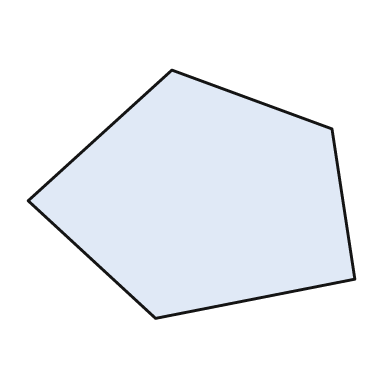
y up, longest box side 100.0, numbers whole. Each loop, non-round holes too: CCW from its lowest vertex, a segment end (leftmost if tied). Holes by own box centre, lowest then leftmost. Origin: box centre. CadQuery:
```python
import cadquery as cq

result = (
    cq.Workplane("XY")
    .moveTo(-11.0, -38.0)
    .lineTo(50.0, -26.0)
    .lineTo(43.0, 20.0)
    .lineTo(-6.0, 38.0)
    .lineTo(-50.0, -2.0)
    .close()
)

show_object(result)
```